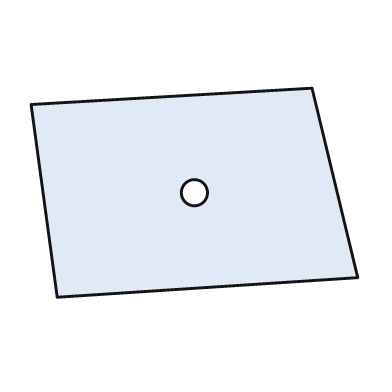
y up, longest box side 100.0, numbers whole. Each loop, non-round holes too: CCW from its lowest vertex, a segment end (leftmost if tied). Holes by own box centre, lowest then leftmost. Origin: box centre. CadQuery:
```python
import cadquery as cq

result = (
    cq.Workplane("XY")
    .moveTo(-42.0, -32.0)
    .lineTo(50.0, -26.0)
    .lineTo(36.0, 32.0)
    .lineTo(-50.0, 27.0)
    .close()
    .moveTo(0.0, 0.0)
    .circle(4.0)
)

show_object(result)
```